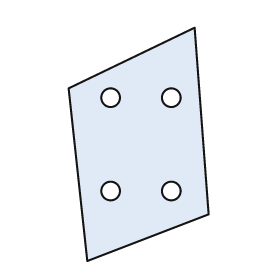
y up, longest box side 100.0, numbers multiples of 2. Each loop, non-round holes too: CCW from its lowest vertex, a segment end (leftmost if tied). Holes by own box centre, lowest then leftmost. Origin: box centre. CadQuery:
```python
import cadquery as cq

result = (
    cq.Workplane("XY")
    .moveTo(-22.0, -50.0)
    .lineTo(30.0, -30.0)
    .lineTo(24.0, 50.0)
    .lineTo(-30.0, 24.0)
    .close()
    .moveTo(-12.0, -20.0)
    .circle(4.0)
    .moveTo(14.0, -20.0)
    .circle(4.0)
    .moveTo(-12.0, 20.0)
    .circle(4.0)
    .moveTo(14.0, 20.0)
    .circle(4.0)
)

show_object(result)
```